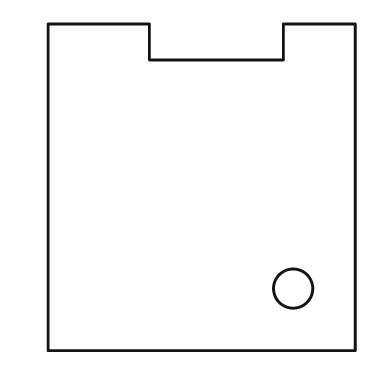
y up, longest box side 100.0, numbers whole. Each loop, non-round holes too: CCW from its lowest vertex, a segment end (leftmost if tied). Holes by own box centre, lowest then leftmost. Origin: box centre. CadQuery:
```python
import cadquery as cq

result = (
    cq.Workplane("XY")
    .moveTo(-47.0, -50.0)
    .lineTo(47.0, -50.0)
    .lineTo(47.0, 50.0)
    .lineTo(25.0, 50.0)
    .lineTo(25.0, 39.0)
    .lineTo(-16.0, 39.0)
    .lineTo(-16.0, 50.0)
    .lineTo(-47.0, 50.0)
    .close()
    .moveTo(28.0, -31.0)
    .circle(6.0)
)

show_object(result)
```